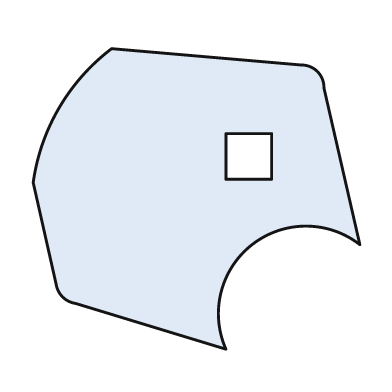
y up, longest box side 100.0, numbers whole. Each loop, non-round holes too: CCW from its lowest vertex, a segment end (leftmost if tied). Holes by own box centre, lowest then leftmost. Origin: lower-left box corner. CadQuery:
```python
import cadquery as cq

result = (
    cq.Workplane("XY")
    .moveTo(59.0, 0.0)
    .threePointArc((67.0, 32.0), (100.0, 32.0))
    .lineTo(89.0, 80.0)
    .threePointArc((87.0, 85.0), (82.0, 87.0))
    .lineTo(24.0, 92.0)
    .threePointArc((8.0, 74.0), (0.0, 51.0))
    .lineTo(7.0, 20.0)
    .threePointArc((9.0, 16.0), (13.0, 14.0))
    .close()
    .moveTo(59.0, 52.0)
    .lineTo(73.0, 52.0)
    .lineTo(73.0, 66.0)
    .lineTo(59.0, 66.0)
    .close()
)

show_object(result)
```